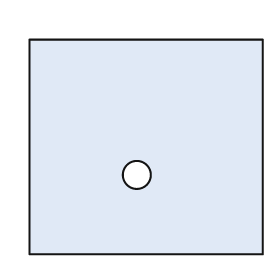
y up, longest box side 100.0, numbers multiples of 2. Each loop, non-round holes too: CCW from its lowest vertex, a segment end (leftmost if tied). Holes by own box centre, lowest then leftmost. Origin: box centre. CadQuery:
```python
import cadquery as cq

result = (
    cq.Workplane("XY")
    .moveTo(-50.0, -46.0)
    .lineTo(50.0, -46.0)
    .lineTo(50.0, 46.0)
    .lineTo(-50.0, 46.0)
    .close()
    .moveTo(-4.0, -12.0)
    .circle(6.0)
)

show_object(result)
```